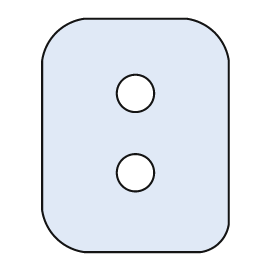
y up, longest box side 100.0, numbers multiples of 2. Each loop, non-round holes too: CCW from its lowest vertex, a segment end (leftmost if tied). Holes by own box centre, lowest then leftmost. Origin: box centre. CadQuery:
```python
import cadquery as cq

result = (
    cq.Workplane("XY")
    .moveTo(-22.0, -50.0)
    .lineTo(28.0, -50.0)
    .threePointArc((36.0, -46.0), (40.0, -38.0))
    .lineTo(40.0, 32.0)
    .threePointArc((34.0, 44.0), (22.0, 50.0))
    .lineTo(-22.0, 50.0)
    .threePointArc((-34.0, 44.0), (-40.0, 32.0))
    .lineTo(-40.0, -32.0)
    .threePointArc((-34.0, -44.0), (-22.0, -50.0))
    .close()
    .moveTo(0.0, -16.0)
    .circle(8.0)
    .moveTo(0.0, 18.0)
    .circle(8.0)
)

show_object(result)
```